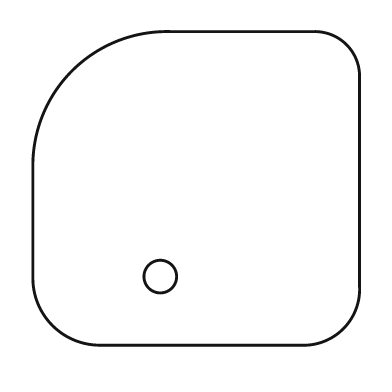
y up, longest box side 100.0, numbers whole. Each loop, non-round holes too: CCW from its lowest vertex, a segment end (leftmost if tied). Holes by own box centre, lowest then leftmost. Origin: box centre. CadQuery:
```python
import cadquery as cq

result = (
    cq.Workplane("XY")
    .moveTo(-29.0, -48.0)
    .lineTo(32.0, -48.0)
    .threePointArc((45.0, -43.0), (50.0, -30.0))
    .lineTo(50.0, 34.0)
    .threePointArc((46.0, 44.0), (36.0, 48.0))
    .lineTo(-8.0, 48.0)
    .threePointArc((-38.0, 36.0), (-50.0, 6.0))
    .lineTo(-50.0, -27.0)
    .threePointArc((-44.0, -42.0), (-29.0, -48.0))
    .close()
    .moveTo(-11.0, -27.0)
    .circle(5.0)
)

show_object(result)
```